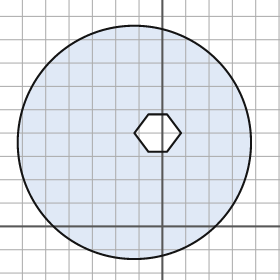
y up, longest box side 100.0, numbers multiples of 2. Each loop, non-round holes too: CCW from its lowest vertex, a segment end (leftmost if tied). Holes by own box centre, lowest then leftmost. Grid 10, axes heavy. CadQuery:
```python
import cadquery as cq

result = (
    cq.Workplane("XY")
    .moveTo(-12.0, 36.0)
    .circle(50.0)
    .moveTo(-6.0, 32.0)
    .lineTo(2.0, 32.0)
    .lineTo(8.0, 40.0)
    .lineTo(2.0, 48.0)
    .lineTo(-6.0, 48.0)
    .lineTo(-12.0, 40.0)
    .close()
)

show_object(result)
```